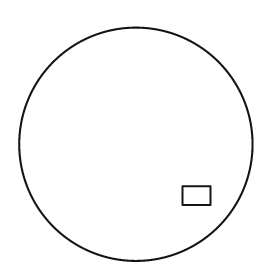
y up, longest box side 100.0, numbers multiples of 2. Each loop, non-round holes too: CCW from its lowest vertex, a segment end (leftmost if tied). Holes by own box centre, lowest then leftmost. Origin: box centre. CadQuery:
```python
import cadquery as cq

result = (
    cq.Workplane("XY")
    .moveTo(0.0, 0.0)
    .circle(50.0)
    .moveTo(20.0, -26.0)
    .lineTo(32.0, -26.0)
    .lineTo(32.0, -18.0)
    .lineTo(20.0, -18.0)
    .close()
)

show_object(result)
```